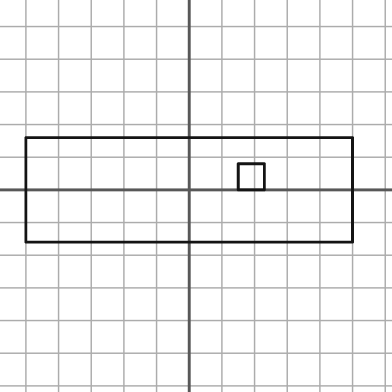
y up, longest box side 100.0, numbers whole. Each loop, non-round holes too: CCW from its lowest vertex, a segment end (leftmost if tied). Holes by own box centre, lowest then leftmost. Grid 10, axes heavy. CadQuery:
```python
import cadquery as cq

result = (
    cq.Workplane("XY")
    .moveTo(-50.0, -16.0)
    .lineTo(50.0, -16.0)
    .lineTo(50.0, 16.0)
    .lineTo(-50.0, 16.0)
    .close()
    .moveTo(15.0, 0.0)
    .lineTo(23.0, 0.0)
    .lineTo(23.0, 8.0)
    .lineTo(15.0, 8.0)
    .close()
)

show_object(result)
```